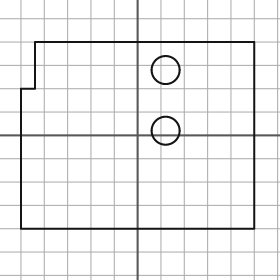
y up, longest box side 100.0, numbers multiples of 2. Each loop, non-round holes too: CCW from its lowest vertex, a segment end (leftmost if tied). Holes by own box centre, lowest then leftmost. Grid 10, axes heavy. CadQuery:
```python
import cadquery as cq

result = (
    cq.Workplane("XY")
    .moveTo(-50.0, -40.0)
    .lineTo(50.0, -40.0)
    .lineTo(50.0, 40.0)
    .lineTo(-44.0, 40.0)
    .lineTo(-44.0, 20.0)
    .lineTo(-50.0, 20.0)
    .close()
    .moveTo(12.0, 2.0)
    .circle(6.0)
    .moveTo(12.0, 28.0)
    .circle(6.0)
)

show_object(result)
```